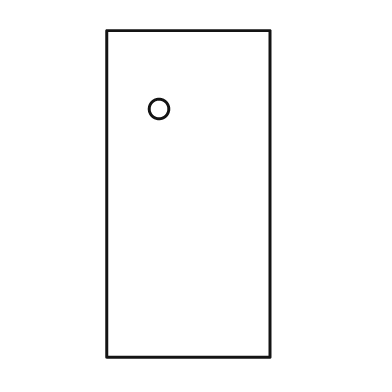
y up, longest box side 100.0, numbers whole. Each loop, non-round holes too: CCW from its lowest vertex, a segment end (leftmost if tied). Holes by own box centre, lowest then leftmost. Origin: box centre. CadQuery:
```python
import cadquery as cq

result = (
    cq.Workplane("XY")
    .moveTo(-25.0, -50.0)
    .lineTo(25.0, -50.0)
    .lineTo(25.0, 50.0)
    .lineTo(-25.0, 50.0)
    .close()
    .moveTo(-9.0, 26.0)
    .circle(3.0)
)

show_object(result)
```